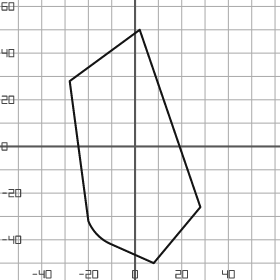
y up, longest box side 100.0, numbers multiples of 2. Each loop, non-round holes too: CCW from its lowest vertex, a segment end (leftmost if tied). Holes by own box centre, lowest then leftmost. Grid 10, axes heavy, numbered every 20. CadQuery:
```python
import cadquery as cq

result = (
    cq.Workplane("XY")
    .moveTo(8.0, -50.0)
    .lineTo(28.0, -26.0)
    .lineTo(2.0, 50.0)
    .lineTo(-28.0, 28.0)
    .lineTo(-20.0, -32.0)
    .threePointArc((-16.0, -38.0), (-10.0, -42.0))
    .close()
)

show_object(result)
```